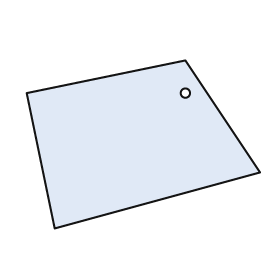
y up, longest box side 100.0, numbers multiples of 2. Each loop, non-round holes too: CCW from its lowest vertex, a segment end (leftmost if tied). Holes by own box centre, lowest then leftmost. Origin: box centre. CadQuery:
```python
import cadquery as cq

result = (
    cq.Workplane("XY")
    .moveTo(-38.0, -36.0)
    .lineTo(50.0, -12.0)
    .lineTo(18.0, 36.0)
    .lineTo(-50.0, 22.0)
    .close()
    .moveTo(18.0, 22.0)
    .circle(2.0)
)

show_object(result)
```